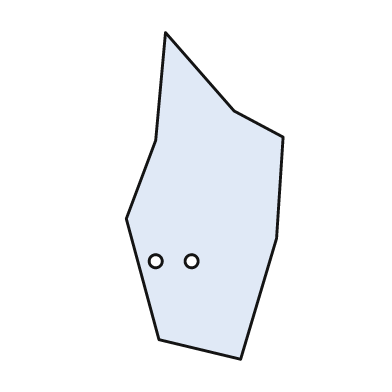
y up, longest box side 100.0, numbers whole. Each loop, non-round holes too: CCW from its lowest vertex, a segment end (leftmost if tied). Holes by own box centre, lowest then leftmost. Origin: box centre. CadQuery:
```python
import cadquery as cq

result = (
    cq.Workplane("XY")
    .moveTo(11.0, -50.0)
    .lineTo(22.0, -13.0)
    .lineTo(24.0, 18.0)
    .lineTo(9.0, 26.0)
    .lineTo(-12.0, 50.0)
    .lineTo(-15.0, 17.0)
    .lineTo(-24.0, -7.0)
    .lineTo(-14.0, -44.0)
    .close()
    .moveTo(-15.0, -20.0)
    .circle(2.0)
    .moveTo(-4.0, -20.0)
    .circle(2.0)
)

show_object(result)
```